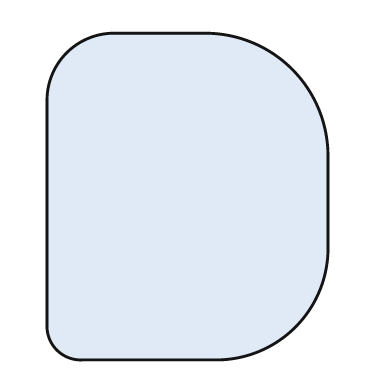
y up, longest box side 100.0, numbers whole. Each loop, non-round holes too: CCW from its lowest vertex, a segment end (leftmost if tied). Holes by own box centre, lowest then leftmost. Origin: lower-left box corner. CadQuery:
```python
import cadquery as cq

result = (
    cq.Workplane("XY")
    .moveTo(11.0, 0.0)
    .lineTo(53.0, 0.0)
    .threePointArc((76.0, 10.0), (86.0, 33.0))
    .lineTo(86.0, 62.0)
    .threePointArc((75.0, 89.0), (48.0, 100.0))
    .lineTo(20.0, 100.0)
    .threePointArc((6.0, 94.0), (0.0, 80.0))
    .lineTo(0.0, 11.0)
    .threePointArc((3.0, 3.0), (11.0, 0.0))
    .close()
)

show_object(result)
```